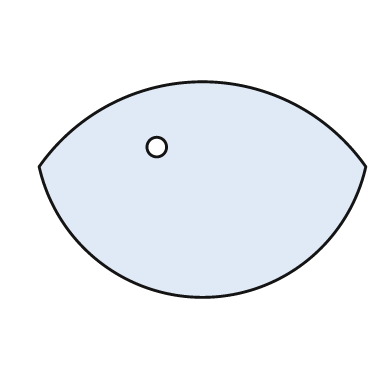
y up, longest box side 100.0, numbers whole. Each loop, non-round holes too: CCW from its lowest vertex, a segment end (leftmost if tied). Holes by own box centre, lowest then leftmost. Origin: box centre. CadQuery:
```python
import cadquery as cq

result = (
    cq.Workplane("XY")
    .moveTo(-50.0, 7.0)
    .threePointArc((0.0, -33.0), (50.0, 7.0))
    .threePointArc((0.0, 33.0), (-50.0, 7.0))
    .close()
    .moveTo(-14.0, 13.0)
    .circle(3.0)
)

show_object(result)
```